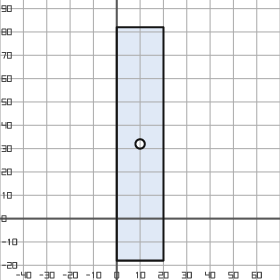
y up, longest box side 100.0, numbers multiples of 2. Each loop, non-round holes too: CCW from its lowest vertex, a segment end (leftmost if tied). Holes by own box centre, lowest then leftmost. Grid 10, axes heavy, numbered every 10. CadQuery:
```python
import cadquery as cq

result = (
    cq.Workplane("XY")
    .moveTo(0.0, -18.0)
    .lineTo(20.0, -18.0)
    .lineTo(20.0, 82.0)
    .lineTo(0.0, 82.0)
    .close()
    .moveTo(10.0, 32.0)
    .circle(2.0)
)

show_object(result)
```